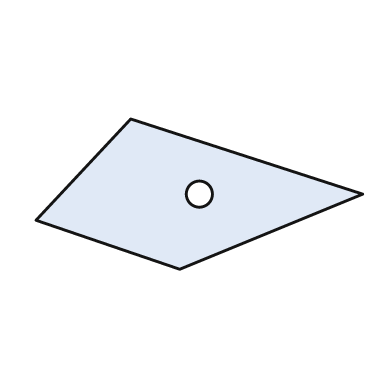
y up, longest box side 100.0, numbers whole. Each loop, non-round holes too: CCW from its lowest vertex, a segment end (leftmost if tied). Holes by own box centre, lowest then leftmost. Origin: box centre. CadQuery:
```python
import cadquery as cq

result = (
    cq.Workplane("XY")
    .moveTo(-6.0, -23.0)
    .lineTo(50.0, 0.0)
    .lineTo(-21.0, 23.0)
    .lineTo(-50.0, -8.0)
    .close()
    .moveTo(0.0, 0.0)
    .circle(4.0)
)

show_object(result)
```